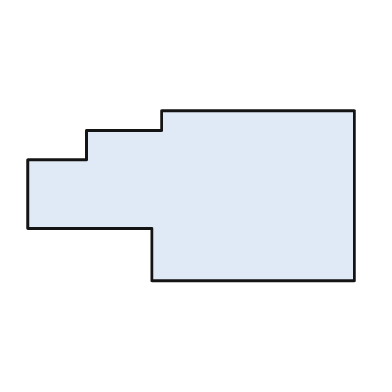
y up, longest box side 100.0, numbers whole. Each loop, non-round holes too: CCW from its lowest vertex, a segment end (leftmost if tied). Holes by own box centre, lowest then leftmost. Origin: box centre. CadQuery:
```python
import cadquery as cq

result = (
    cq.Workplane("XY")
    .moveTo(-12.0, -26.0)
    .lineTo(50.0, -26.0)
    .lineTo(50.0, 26.0)
    .lineTo(-9.0, 26.0)
    .lineTo(-9.0, 20.0)
    .lineTo(-32.0, 20.0)
    .lineTo(-32.0, 11.0)
    .lineTo(-50.0, 11.0)
    .lineTo(-50.0, -10.0)
    .lineTo(-12.0, -10.0)
    .close()
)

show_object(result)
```